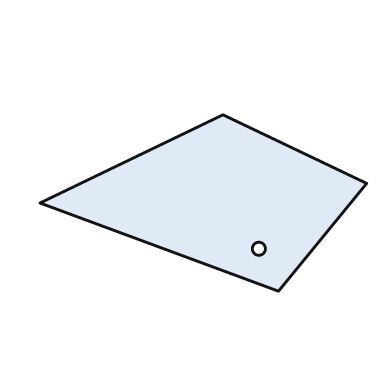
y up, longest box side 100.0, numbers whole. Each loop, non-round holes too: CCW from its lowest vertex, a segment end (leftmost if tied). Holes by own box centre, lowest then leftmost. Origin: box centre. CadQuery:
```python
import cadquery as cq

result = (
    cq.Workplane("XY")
    .moveTo(23.0, -27.0)
    .lineTo(50.0, 6.0)
    .lineTo(6.0, 27.0)
    .lineTo(-50.0, 0.0)
    .close()
    .moveTo(17.0, -14.0)
    .circle(2.0)
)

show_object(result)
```